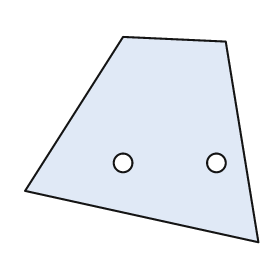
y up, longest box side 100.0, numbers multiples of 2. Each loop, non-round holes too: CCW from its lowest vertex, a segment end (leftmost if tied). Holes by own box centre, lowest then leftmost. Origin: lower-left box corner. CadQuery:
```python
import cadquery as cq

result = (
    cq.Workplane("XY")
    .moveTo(100.0, 0.0)
    .lineTo(86.0, 86.0)
    .lineTo(42.0, 88.0)
    .lineTo(0.0, 22.0)
    .close()
    .moveTo(42.0, 34.0)
    .circle(4.0)
    .moveTo(82.0, 34.0)
    .circle(4.0)
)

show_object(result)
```